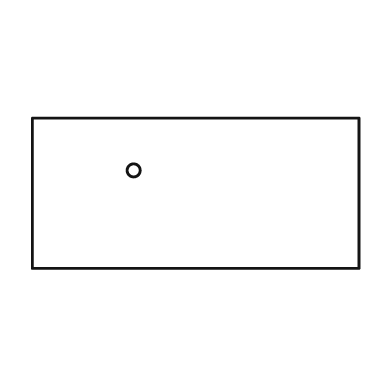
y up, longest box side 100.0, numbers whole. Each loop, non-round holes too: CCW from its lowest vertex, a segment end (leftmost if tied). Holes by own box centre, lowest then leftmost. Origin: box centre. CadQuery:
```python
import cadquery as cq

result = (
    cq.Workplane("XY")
    .moveTo(-50.0, -23.0)
    .lineTo(50.0, -23.0)
    .lineTo(50.0, 23.0)
    .lineTo(-50.0, 23.0)
    .close()
    .moveTo(-19.0, 7.0)
    .circle(2.0)
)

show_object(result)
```